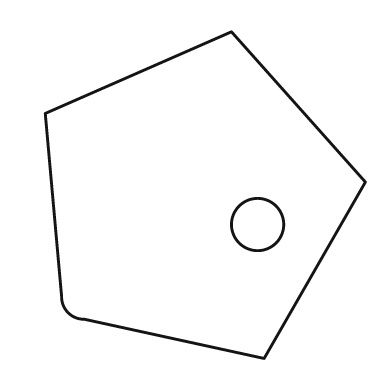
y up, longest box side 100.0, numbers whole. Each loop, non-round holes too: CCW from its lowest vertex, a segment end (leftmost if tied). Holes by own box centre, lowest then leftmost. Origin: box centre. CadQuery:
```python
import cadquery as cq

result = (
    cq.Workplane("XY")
    .moveTo(18.0, -50.0)
    .lineTo(49.0, 4.0)
    .lineTo(8.0, 50.0)
    .lineTo(-49.0, 25.0)
    .lineTo(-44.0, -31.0)
    .threePointArc((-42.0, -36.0), (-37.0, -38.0))
    .close()
    .moveTo(16.0, -9.0)
    .circle(8.0)
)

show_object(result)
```